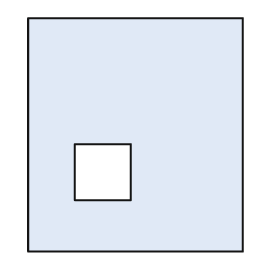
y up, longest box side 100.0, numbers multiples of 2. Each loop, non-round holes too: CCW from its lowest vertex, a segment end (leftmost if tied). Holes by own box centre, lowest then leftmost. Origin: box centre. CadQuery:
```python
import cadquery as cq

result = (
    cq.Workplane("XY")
    .moveTo(-46.0, -50.0)
    .lineTo(46.0, -50.0)
    .lineTo(46.0, 50.0)
    .lineTo(-46.0, 50.0)
    .close()
    .moveTo(-26.0, -28.0)
    .lineTo(-2.0, -28.0)
    .lineTo(-2.0, -4.0)
    .lineTo(-26.0, -4.0)
    .close()
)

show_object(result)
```